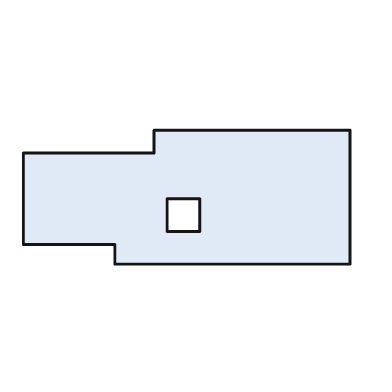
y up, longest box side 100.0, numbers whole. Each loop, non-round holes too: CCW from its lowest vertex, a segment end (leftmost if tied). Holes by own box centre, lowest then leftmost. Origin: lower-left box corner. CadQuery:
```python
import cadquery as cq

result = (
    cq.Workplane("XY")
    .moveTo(28.0, 0.0)
    .lineTo(100.0, 0.0)
    .lineTo(100.0, 41.0)
    .lineTo(40.0, 41.0)
    .lineTo(40.0, 34.0)
    .lineTo(0.0, 34.0)
    .lineTo(0.0, 6.0)
    .lineTo(28.0, 6.0)
    .close()
    .moveTo(44.0, 10.0)
    .lineTo(54.0, 10.0)
    .lineTo(54.0, 20.0)
    .lineTo(44.0, 20.0)
    .close()
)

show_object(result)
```